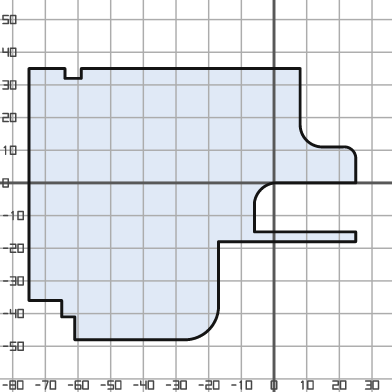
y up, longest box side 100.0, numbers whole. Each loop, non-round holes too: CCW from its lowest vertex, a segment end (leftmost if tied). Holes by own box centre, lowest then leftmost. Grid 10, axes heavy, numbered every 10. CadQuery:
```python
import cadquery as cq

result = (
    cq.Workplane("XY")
    .moveTo(-61.0, -48.0)
    .lineTo(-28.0, -48.0)
    .threePointArc((-20.0, -45.0), (-17.0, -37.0))
    .lineTo(-17.0, -18.0)
    .lineTo(25.0, -18.0)
    .lineTo(25.0, -15.0)
    .lineTo(-6.0, -15.0)
    .lineTo(-6.0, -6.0)
    .threePointArc((-4.0, -2.0), (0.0, 0.0))
    .lineTo(25.0, 0.0)
    .lineTo(25.0, 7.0)
    .threePointArc((24.0, 10.0), (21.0, 11.0))
    .lineTo(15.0, 11.0)
    .threePointArc((10.0, 13.0), (8.0, 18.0))
    .lineTo(8.0, 35.0)
    .lineTo(-59.0, 35.0)
    .lineTo(-59.0, 32.0)
    .lineTo(-64.0, 32.0)
    .lineTo(-64.0, 35.0)
    .lineTo(-75.0, 35.0)
    .lineTo(-75.0, -36.0)
    .lineTo(-65.0, -36.0)
    .lineTo(-65.0, -41.0)
    .lineTo(-61.0, -41.0)
    .close()
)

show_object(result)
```